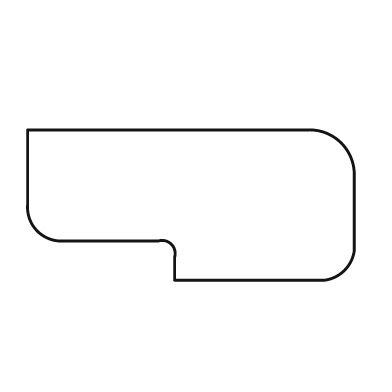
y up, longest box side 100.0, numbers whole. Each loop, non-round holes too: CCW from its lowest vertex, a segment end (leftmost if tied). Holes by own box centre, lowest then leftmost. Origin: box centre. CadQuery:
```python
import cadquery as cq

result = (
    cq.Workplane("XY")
    .moveTo(-5.0, -23.0)
    .lineTo(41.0, -23.0)
    .threePointArc((47.0, -20.0), (50.0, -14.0))
    .lineTo(50.0, 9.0)
    .threePointArc((46.0, 19.0), (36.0, 23.0))
    .lineTo(-50.0, 23.0)
    .lineTo(-50.0, 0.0)
    .threePointArc((-47.0, -8.0), (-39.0, -11.0))
    .lineTo(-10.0, -11.0)
    .threePointArc((-6.0, -12.0), (-5.0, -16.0))
    .close()
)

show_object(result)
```